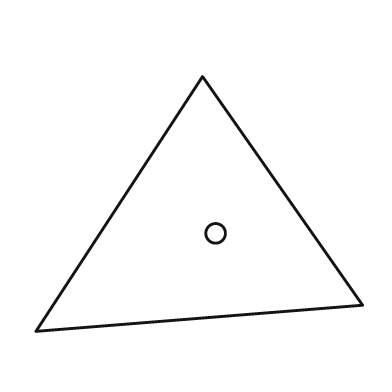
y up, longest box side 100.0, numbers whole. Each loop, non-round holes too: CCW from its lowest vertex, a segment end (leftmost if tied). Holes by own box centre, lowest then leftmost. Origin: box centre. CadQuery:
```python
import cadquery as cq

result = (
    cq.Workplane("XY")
    .moveTo(-50.0, -39.0)
    .lineTo(50.0, -31.0)
    .lineTo(1.0, 39.0)
    .close()
    .moveTo(5.0, -9.0)
    .circle(3.0)
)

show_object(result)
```